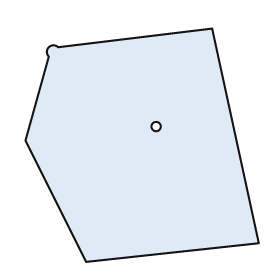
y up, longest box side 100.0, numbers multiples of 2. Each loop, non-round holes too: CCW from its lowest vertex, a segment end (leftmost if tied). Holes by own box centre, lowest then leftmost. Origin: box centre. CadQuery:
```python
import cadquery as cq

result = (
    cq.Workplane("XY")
    .moveTo(-24.0, -50.0)
    .lineTo(50.0, -42.0)
    .lineTo(30.0, 50.0)
    .lineTo(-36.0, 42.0)
    .threePointArc((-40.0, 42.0), (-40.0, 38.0))
    .lineTo(-50.0, 2.0)
    .close()
    .moveTo(6.0, 8.0)
    .circle(2.0)
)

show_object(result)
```